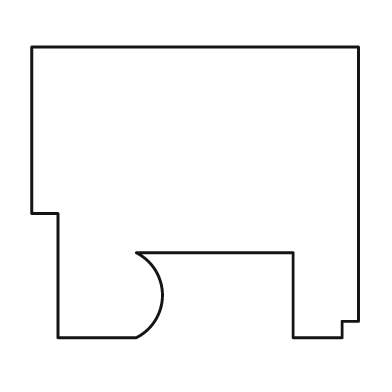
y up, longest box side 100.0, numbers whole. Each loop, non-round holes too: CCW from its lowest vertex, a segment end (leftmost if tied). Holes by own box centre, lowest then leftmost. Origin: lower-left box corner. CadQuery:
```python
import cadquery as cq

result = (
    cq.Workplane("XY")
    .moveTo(8.0, 0.0)
    .lineTo(32.0, 0.0)
    .threePointArc((40.0, 13.0), (32.0, 26.0))
    .lineTo(80.0, 26.0)
    .lineTo(80.0, 0.0)
    .lineTo(95.0, 0.0)
    .lineTo(95.0, 5.0)
    .lineTo(100.0, 5.0)
    .lineTo(100.0, 89.0)
    .lineTo(0.0, 89.0)
    .lineTo(0.0, 38.0)
    .lineTo(8.0, 38.0)
    .close()
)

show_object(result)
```